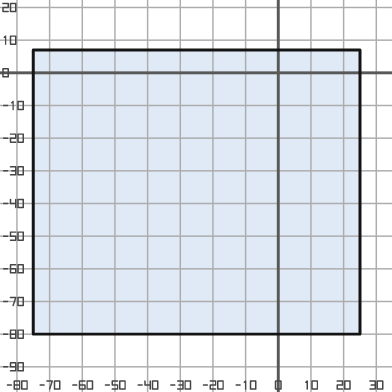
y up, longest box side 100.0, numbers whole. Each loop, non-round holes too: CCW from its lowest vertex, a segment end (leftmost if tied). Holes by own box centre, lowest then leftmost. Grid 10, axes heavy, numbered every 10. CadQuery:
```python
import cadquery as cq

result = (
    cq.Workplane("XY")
    .moveTo(-75.0, -80.0)
    .lineTo(25.0, -80.0)
    .lineTo(25.0, 7.0)
    .lineTo(-75.0, 7.0)
    .close()
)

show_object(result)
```